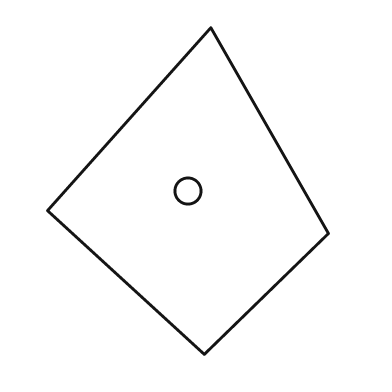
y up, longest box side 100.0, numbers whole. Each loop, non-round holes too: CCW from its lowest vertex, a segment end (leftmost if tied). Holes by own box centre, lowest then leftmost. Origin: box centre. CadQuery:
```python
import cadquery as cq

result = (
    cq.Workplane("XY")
    .moveTo(5.0, -50.0)
    .lineTo(43.0, -13.0)
    .lineTo(7.0, 50.0)
    .lineTo(-43.0, -6.0)
    .close()
    .moveTo(0.0, 0.0)
    .circle(4.0)
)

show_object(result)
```